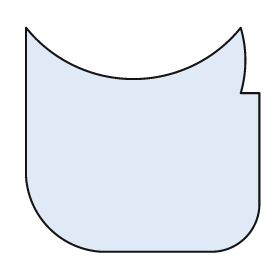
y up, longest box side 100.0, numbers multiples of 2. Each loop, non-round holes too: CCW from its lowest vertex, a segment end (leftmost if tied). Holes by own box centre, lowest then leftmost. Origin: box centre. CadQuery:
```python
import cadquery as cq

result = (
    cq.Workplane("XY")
    .moveTo(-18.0, -48.0)
    .lineTo(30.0, -48.0)
    .threePointArc((44.0, -42.0), (50.0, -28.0))
    .lineTo(50.0, 20.0)
    .lineTo(42.0, 20.0)
    .threePointArc((44.0, 34.0), (42.0, 48.0))
    .threePointArc((-4.0, 26.0), (-50.0, 48.0))
    .lineTo(-50.0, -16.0)
    .threePointArc((-40.0, -38.0), (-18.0, -48.0))
    .close()
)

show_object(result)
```